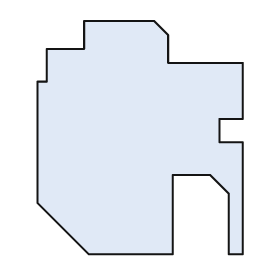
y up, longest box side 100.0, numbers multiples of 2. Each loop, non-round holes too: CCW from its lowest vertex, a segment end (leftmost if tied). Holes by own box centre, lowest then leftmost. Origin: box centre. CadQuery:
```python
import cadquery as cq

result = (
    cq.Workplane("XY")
    .moveTo(-22.0, -50.0)
    .lineTo(14.0, -50.0)
    .lineTo(14.0, -16.0)
    .lineTo(30.0, -16.0)
    .lineTo(38.0, -24.0)
    .lineTo(38.0, -50.0)
    .lineTo(44.0, -50.0)
    .lineTo(44.0, -2.0)
    .lineTo(34.0, -2.0)
    .lineTo(34.0, 8.0)
    .lineTo(44.0, 8.0)
    .lineTo(44.0, 32.0)
    .lineTo(12.0, 32.0)
    .lineTo(12.0, 44.0)
    .lineTo(6.0, 50.0)
    .lineTo(-24.0, 50.0)
    .lineTo(-24.0, 38.0)
    .lineTo(-40.0, 38.0)
    .lineTo(-40.0, 24.0)
    .lineTo(-44.0, 24.0)
    .lineTo(-44.0, -28.0)
    .close()
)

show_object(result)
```